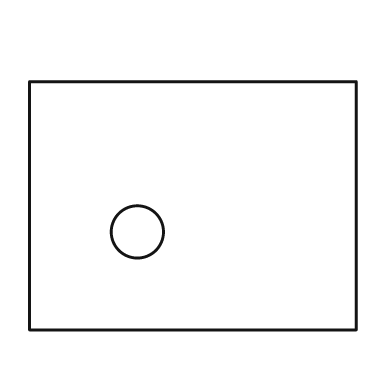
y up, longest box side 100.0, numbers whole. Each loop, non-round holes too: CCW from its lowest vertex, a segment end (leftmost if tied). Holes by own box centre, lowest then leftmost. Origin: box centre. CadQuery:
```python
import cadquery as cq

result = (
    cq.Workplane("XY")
    .moveTo(-50.0, -38.0)
    .lineTo(50.0, -38.0)
    .lineTo(50.0, 38.0)
    .lineTo(-50.0, 38.0)
    .close()
    .moveTo(-17.0, -8.0)
    .circle(8.0)
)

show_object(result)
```